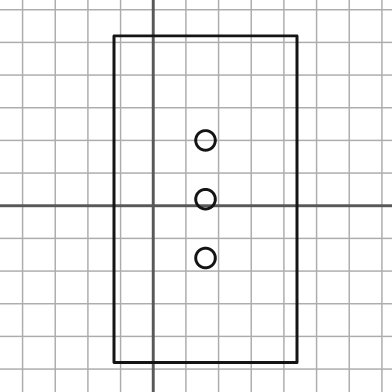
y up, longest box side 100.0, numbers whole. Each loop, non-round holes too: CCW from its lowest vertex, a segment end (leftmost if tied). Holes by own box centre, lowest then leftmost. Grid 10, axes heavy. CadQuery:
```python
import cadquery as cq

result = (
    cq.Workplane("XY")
    .moveTo(-12.0, -48.0)
    .lineTo(44.0, -48.0)
    .lineTo(44.0, 52.0)
    .lineTo(-12.0, 52.0)
    .close()
    .moveTo(16.0, -16.0)
    .circle(3.0)
    .moveTo(16.0, 2.0)
    .circle(3.0)
    .moveTo(16.0, 20.0)
    .circle(3.0)
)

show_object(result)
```